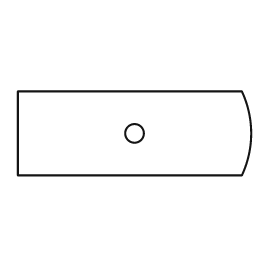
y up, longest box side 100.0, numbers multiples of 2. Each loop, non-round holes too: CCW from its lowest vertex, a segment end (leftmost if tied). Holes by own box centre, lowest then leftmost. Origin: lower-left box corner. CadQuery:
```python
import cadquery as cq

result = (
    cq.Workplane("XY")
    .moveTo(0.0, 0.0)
    .lineTo(96.0, 0.0)
    .threePointArc((100.0, 18.0), (96.0, 36.0))
    .lineTo(0.0, 36.0)
    .close()
    .moveTo(50.0, 18.0)
    .circle(4.0)
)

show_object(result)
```